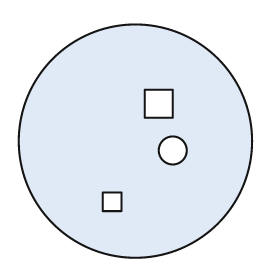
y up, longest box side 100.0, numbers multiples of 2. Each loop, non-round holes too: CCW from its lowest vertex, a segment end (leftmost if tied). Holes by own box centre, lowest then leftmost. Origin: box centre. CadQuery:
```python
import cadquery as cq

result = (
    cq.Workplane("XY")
    .moveTo(0.0, 0.0)
    .circle(50.0)
    .moveTo(-14.0, -30.0)
    .lineTo(-6.0, -30.0)
    .lineTo(-6.0, -22.0)
    .lineTo(-14.0, -22.0)
    .close()
    .moveTo(16.0, -4.0)
    .circle(6.0)
    .moveTo(4.0, 10.0)
    .lineTo(16.0, 10.0)
    .lineTo(16.0, 22.0)
    .lineTo(4.0, 22.0)
    .close()
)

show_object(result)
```